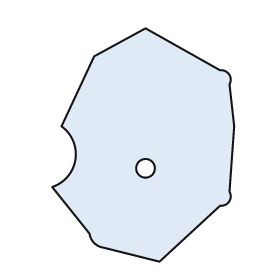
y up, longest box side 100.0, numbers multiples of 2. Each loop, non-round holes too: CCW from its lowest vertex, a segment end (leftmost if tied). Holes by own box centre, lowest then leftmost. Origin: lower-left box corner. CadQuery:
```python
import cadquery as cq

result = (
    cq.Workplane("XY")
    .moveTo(46.0, 0.0)
    .lineTo(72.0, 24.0)
    .threePointArc((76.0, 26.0), (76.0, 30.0))
    .lineTo(78.0, 58.0)
    .lineTo(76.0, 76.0)
    .threePointArc((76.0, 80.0), (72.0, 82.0))
    .lineTo(40.0, 100.0)
    .lineTo(18.0, 88.0)
    .lineTo(4.0, 58.0)
    .threePointArc((10.0, 44.0), (0.0, 32.0))
    .lineTo(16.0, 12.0)
    .threePointArc((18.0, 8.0), (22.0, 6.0))
    .close()
    .moveTo(40.0, 40.0)
    .circle(4.0)
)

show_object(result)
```